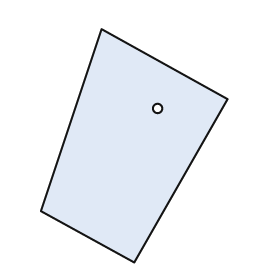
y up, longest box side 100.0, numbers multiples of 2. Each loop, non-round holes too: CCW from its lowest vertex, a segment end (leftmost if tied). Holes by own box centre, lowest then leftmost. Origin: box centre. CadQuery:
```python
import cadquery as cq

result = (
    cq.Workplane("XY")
    .moveTo(0.0, -50.0)
    .lineTo(40.0, 20.0)
    .lineTo(-14.0, 50.0)
    .lineTo(-40.0, -28.0)
    .close()
    .moveTo(10.0, 16.0)
    .circle(2.0)
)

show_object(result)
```